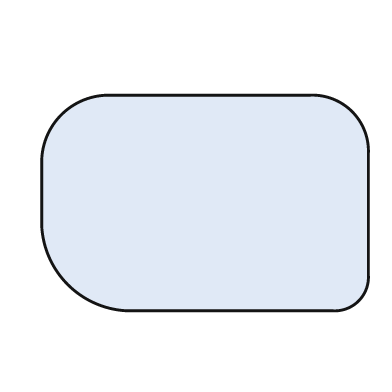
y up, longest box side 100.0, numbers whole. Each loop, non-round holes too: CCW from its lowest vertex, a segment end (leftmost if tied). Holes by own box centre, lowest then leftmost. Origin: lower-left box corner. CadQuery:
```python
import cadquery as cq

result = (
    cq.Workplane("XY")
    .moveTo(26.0, 0.0)
    .lineTo(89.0, 0.0)
    .threePointArc((97.0, 3.0), (100.0, 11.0))
    .lineTo(100.0, 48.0)
    .threePointArc((95.0, 61.0), (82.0, 66.0))
    .lineTo(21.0, 66.0)
    .threePointArc((6.0, 60.0), (0.0, 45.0))
    .lineTo(0.0, 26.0)
    .threePointArc((8.0, 8.0), (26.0, 0.0))
    .close()
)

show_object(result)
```